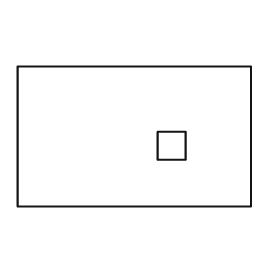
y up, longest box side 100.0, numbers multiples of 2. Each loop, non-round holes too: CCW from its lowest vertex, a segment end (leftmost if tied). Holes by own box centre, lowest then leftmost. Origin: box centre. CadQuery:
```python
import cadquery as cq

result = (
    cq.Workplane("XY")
    .moveTo(-50.0, -30.0)
    .lineTo(50.0, -30.0)
    .lineTo(50.0, 30.0)
    .lineTo(-50.0, 30.0)
    .close()
    .moveTo(10.0, -10.0)
    .lineTo(22.0, -10.0)
    .lineTo(22.0, 2.0)
    .lineTo(10.0, 2.0)
    .close()
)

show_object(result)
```